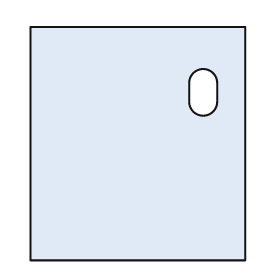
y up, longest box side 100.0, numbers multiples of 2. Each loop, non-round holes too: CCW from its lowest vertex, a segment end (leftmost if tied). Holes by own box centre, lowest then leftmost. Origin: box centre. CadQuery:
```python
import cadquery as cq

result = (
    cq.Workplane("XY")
    .moveTo(-46.0, -50.0)
    .lineTo(46.0, -50.0)
    .lineTo(46.0, 50.0)
    .lineTo(-46.0, 50.0)
    .close()
    .moveTo(22.0, 18.0)
    .threePointArc((28.0, 12.0), (34.0, 18.0))
    .lineTo(34.0, 26.0)
    .threePointArc((28.0, 32.0), (22.0, 26.0))
    .close()
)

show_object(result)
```